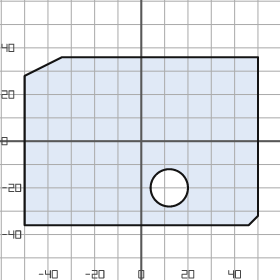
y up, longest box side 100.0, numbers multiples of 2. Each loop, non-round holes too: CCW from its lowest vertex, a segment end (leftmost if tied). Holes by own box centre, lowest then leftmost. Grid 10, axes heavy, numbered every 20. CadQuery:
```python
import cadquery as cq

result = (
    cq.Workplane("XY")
    .moveTo(-50.0, -36.0)
    .lineTo(46.0, -36.0)
    .lineTo(50.0, -32.0)
    .lineTo(50.0, 36.0)
    .lineTo(-34.0, 36.0)
    .lineTo(-50.0, 28.0)
    .close()
    .moveTo(12.0, -20.0)
    .circle(8.0)
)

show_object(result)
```